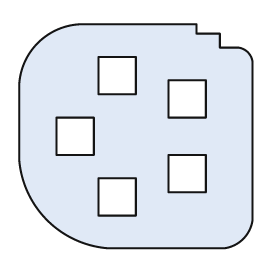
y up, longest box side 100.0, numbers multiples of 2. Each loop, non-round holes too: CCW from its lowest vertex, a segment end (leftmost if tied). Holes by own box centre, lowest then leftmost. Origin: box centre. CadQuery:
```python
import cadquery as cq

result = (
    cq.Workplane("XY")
    .moveTo(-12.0, -48.0)
    .lineTo(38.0, -48.0)
    .threePointArc((46.0, -44.0), (50.0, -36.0))
    .lineTo(50.0, 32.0)
    .threePointArc((48.0, 36.0), (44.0, 38.0))
    .lineTo(36.0, 38.0)
    .lineTo(36.0, 44.0)
    .lineTo(26.0, 44.0)
    .lineTo(26.0, 48.0)
    .lineTo(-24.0, 48.0)
    .threePointArc((-42.0, 40.0), (-50.0, 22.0))
    .lineTo(-50.0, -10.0)
    .threePointArc((-38.0, -36.0), (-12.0, -48.0))
    .close()
    .moveTo(-16.0, -34.0)
    .lineTo(0.0, -34.0)
    .lineTo(0.0, -18.0)
    .lineTo(-16.0, -18.0)
    .close()
    .moveTo(14.0, -24.0)
    .lineTo(30.0, -24.0)
    .lineTo(30.0, -8.0)
    .lineTo(14.0, -8.0)
    .close()
    .moveTo(-34.0, -8.0)
    .lineTo(-18.0, -8.0)
    .lineTo(-18.0, 8.0)
    .lineTo(-34.0, 8.0)
    .close()
    .moveTo(14.0, 8.0)
    .lineTo(30.0, 8.0)
    .lineTo(30.0, 24.0)
    .lineTo(14.0, 24.0)
    .close()
    .moveTo(-16.0, 18.0)
    .lineTo(0.0, 18.0)
    .lineTo(0.0, 34.0)
    .lineTo(-16.0, 34.0)
    .close()
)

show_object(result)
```